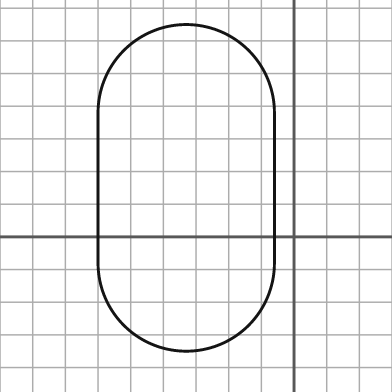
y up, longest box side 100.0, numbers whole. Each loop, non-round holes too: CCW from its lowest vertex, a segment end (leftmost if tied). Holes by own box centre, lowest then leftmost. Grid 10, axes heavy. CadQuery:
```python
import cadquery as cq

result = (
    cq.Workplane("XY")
    .moveTo(-60.0, -8.0)
    .threePointArc((-33.0, -35.0), (-6.0, -8.0))
    .lineTo(-6.0, 38.0)
    .threePointArc((-33.0, 65.0), (-60.0, 38.0))
    .close()
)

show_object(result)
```